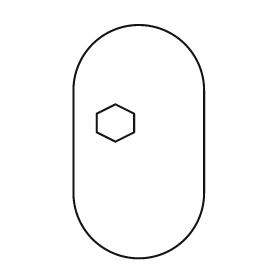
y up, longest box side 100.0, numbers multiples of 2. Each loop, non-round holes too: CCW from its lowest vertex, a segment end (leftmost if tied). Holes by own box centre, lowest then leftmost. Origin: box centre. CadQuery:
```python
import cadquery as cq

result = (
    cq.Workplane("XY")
    .moveTo(-28.0, -22.0)
    .threePointArc((0.0, -50.0), (28.0, -22.0))
    .lineTo(28.0, 22.0)
    .threePointArc((0.0, 50.0), (-28.0, 22.0))
    .close()
    .moveTo(-10.0, 0.0)
    .lineTo(-2.0, 4.0)
    .lineTo(-2.0, 12.0)
    .lineTo(-10.0, 16.0)
    .lineTo(-18.0, 12.0)
    .lineTo(-18.0, 4.0)
    .close()
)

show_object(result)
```